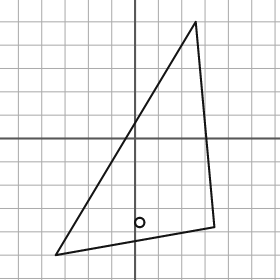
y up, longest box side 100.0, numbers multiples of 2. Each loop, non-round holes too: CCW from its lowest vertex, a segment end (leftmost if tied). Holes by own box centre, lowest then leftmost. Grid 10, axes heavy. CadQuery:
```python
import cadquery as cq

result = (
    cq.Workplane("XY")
    .moveTo(-34.0, -50.0)
    .lineTo(34.0, -38.0)
    .lineTo(26.0, 50.0)
    .close()
    .moveTo(2.0, -36.0)
    .circle(2.0)
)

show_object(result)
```